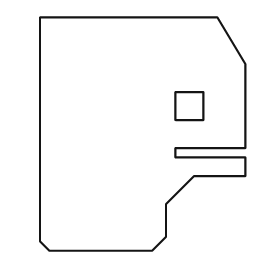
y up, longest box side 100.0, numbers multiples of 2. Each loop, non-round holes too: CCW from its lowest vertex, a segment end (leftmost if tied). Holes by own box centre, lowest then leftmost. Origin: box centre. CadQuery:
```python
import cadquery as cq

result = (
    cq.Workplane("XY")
    .moveTo(-40.0, -50.0)
    .lineTo(4.0, -50.0)
    .lineTo(10.0, -44.0)
    .lineTo(10.0, -30.0)
    .lineTo(22.0, -18.0)
    .lineTo(44.0, -18.0)
    .lineTo(44.0, -10.0)
    .lineTo(14.0, -10.0)
    .lineTo(14.0, -6.0)
    .lineTo(44.0, -6.0)
    .lineTo(44.0, 30.0)
    .lineTo(32.0, 50.0)
    .lineTo(-44.0, 50.0)
    .lineTo(-44.0, -46.0)
    .close()
    .moveTo(14.0, 6.0)
    .lineTo(26.0, 6.0)
    .lineTo(26.0, 18.0)
    .lineTo(14.0, 18.0)
    .close()
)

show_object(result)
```